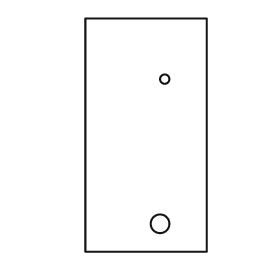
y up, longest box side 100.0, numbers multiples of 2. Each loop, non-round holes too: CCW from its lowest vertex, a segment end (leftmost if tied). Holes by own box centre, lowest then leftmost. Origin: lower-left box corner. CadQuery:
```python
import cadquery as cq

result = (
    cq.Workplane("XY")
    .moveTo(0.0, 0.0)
    .lineTo(52.0, 0.0)
    .lineTo(52.0, 100.0)
    .lineTo(0.0, 100.0)
    .close()
    .moveTo(32.0, 12.0)
    .circle(4.0)
    .moveTo(34.0, 74.0)
    .circle(2.0)
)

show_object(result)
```